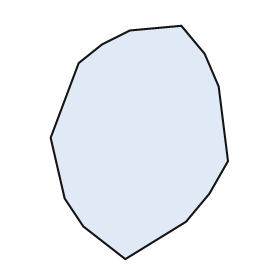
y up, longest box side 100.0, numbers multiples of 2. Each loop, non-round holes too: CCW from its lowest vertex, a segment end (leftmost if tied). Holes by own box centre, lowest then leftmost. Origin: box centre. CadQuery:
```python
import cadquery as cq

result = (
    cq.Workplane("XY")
    .moveTo(-6.0, -50.0)
    .lineTo(20.0, -34.0)
    .lineTo(30.0, -22.0)
    .lineTo(38.0, -8.0)
    .lineTo(34.0, 24.0)
    .lineTo(28.0, 38.0)
    .lineTo(18.0, 50.0)
    .lineTo(-4.0, 48.0)
    .lineTo(-16.0, 42.0)
    .lineTo(-26.0, 34.0)
    .lineTo(-38.0, 2.0)
    .lineTo(-32.0, -24.0)
    .lineTo(-24.0, -36.0)
    .close()
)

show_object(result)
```